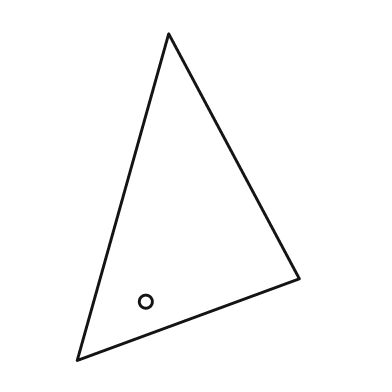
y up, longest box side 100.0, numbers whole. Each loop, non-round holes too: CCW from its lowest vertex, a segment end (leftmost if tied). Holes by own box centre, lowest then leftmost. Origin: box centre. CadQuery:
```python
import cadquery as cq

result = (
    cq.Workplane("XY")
    .moveTo(-34.0, -50.0)
    .lineTo(34.0, -25.0)
    .lineTo(-6.0, 50.0)
    .close()
    .moveTo(-13.0, -32.0)
    .circle(2.0)
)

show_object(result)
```